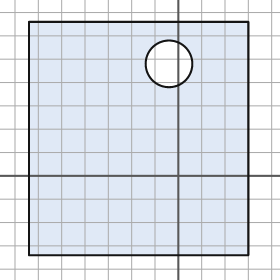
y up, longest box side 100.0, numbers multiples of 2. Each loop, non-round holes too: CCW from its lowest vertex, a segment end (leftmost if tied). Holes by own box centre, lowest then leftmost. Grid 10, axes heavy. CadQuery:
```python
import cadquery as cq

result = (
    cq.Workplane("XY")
    .moveTo(-64.0, -34.0)
    .lineTo(30.0, -34.0)
    .lineTo(30.0, 66.0)
    .lineTo(-64.0, 66.0)
    .close()
    .moveTo(-4.0, 48.0)
    .circle(10.0)
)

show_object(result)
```